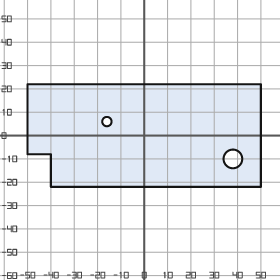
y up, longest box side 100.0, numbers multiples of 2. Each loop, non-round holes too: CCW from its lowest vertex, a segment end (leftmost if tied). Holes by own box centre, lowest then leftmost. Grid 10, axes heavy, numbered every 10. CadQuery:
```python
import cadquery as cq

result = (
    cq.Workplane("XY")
    .moveTo(-40.0, -22.0)
    .lineTo(50.0, -22.0)
    .lineTo(50.0, 22.0)
    .lineTo(-50.0, 22.0)
    .lineTo(-50.0, -8.0)
    .lineTo(-40.0, -8.0)
    .close()
    .moveTo(38.0, -10.0)
    .circle(4.0)
    .moveTo(-16.0, 6.0)
    .circle(2.0)
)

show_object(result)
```